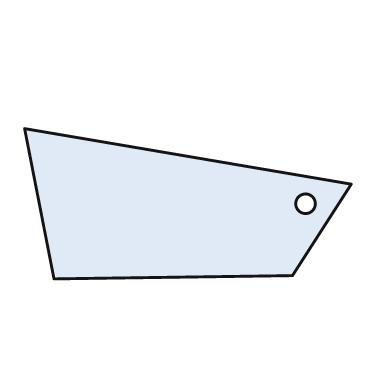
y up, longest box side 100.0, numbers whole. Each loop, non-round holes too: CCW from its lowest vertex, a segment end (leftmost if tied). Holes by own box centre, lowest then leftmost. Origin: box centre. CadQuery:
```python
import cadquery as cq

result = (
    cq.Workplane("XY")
    .moveTo(-41.0, -23.0)
    .lineTo(32.0, -22.0)
    .lineTo(50.0, 6.0)
    .lineTo(-50.0, 23.0)
    .close()
    .moveTo(36.0, 0.0)
    .circle(3.0)
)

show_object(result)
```